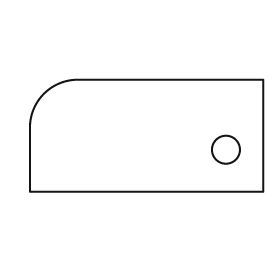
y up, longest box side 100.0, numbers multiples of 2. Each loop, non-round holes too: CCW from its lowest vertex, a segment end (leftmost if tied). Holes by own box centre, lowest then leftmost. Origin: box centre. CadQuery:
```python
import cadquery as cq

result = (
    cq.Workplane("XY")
    .moveTo(-50.0, -24.0)
    .lineTo(50.0, -24.0)
    .lineTo(50.0, 24.0)
    .lineTo(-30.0, 24.0)
    .threePointArc((-44.0, 18.0), (-50.0, 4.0))
    .close()
    .moveTo(34.0, -6.0)
    .circle(6.0)
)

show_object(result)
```